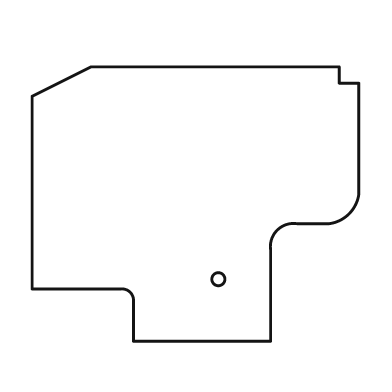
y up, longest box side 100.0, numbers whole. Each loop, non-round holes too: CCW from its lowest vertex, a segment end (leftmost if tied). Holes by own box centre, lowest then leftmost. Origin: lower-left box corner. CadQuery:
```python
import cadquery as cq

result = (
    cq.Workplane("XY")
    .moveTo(31.0, 0.0)
    .lineTo(73.0, 0.0)
    .lineTo(73.0, 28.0)
    .threePointArc((75.0, 34.0), (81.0, 36.0))
    .lineTo(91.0, 36.0)
    .threePointArc((97.0, 39.0), (100.0, 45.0))
    .lineTo(100.0, 79.0)
    .lineTo(94.0, 79.0)
    .lineTo(94.0, 84.0)
    .lineTo(18.0, 84.0)
    .lineTo(0.0, 75.0)
    .lineTo(0.0, 16.0)
    .lineTo(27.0, 16.0)
    .threePointArc((30.0, 15.0), (31.0, 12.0))
    .close()
    .moveTo(57.0, 19.0)
    .circle(2.0)
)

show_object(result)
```